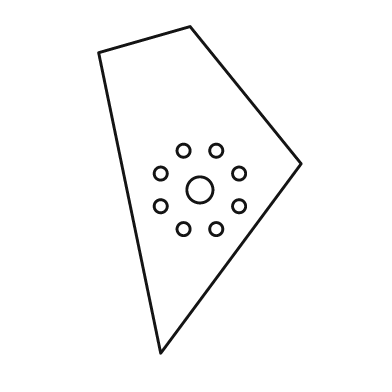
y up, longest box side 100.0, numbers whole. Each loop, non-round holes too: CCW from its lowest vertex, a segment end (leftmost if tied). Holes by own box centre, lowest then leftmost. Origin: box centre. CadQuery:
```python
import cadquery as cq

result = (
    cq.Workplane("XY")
    .moveTo(-12.0, -50.0)
    .lineTo(31.0, 8.0)
    .lineTo(-3.0, 50.0)
    .lineTo(-31.0, 42.0)
    .close()
    .moveTo(-5.0, -12.0)
    .circle(2.0)
    .moveTo(5.0, -12.0)
    .circle(2.0)
    .moveTo(-12.0, -5.0)
    .circle(2.0)
    .moveTo(12.0, -5.0)
    .circle(2.0)
    .moveTo(0.0, 0.0)
    .circle(4.0)
    .moveTo(-12.0, 5.0)
    .circle(2.0)
    .moveTo(12.0, 5.0)
    .circle(2.0)
    .moveTo(-5.0, 12.0)
    .circle(2.0)
    .moveTo(5.0, 12.0)
    .circle(2.0)
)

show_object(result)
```